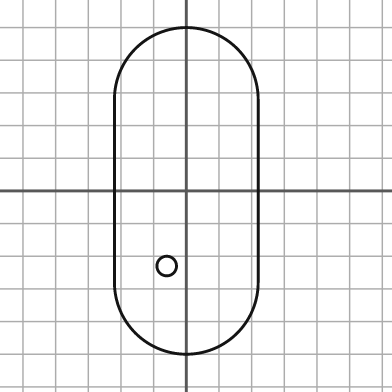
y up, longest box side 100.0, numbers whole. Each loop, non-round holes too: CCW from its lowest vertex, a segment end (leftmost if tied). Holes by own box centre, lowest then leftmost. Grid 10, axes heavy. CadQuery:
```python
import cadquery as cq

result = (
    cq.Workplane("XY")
    .moveTo(-22.0, -28.0)
    .threePointArc((0.0, -50.0), (22.0, -28.0))
    .lineTo(22.0, 28.0)
    .threePointArc((0.0, 50.0), (-22.0, 28.0))
    .close()
    .moveTo(-6.0, -23.0)
    .circle(3.0)
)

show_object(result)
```